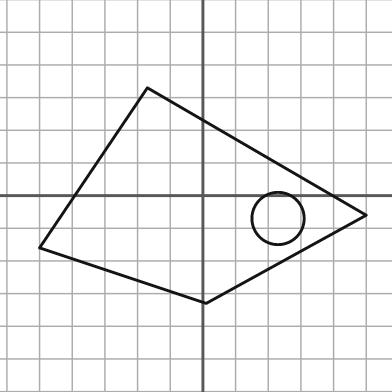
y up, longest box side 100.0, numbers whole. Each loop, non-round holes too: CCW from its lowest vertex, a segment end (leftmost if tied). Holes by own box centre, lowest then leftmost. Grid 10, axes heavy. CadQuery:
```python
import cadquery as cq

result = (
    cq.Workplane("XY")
    .moveTo(1.0, -33.0)
    .lineTo(50.0, -6.0)
    .lineTo(-17.0, 33.0)
    .lineTo(-50.0, -16.0)
    .close()
    .moveTo(23.0, -7.0)
    .circle(8.0)
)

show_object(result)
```